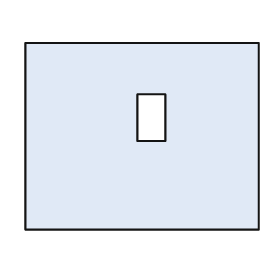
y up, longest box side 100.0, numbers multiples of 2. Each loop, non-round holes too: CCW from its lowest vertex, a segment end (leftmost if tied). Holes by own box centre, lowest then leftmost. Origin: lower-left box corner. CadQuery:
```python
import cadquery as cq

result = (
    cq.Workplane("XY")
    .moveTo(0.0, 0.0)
    .lineTo(100.0, 0.0)
    .lineTo(100.0, 80.0)
    .lineTo(0.0, 80.0)
    .close()
    .moveTo(48.0, 38.0)
    .lineTo(60.0, 38.0)
    .lineTo(60.0, 58.0)
    .lineTo(48.0, 58.0)
    .close()
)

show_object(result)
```